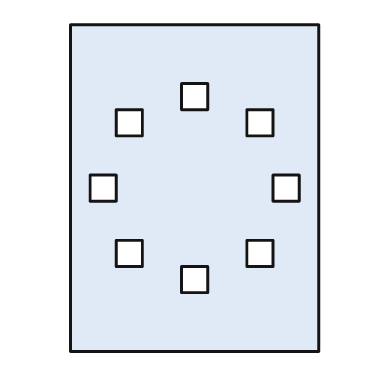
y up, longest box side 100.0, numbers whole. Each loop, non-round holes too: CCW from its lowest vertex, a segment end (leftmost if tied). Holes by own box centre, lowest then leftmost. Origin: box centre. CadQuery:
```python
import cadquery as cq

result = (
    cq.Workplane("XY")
    .moveTo(-38.0, -50.0)
    .lineTo(38.0, -50.0)
    .lineTo(38.0, 50.0)
    .lineTo(-38.0, 50.0)
    .close()
    .moveTo(-4.0, -32.0)
    .lineTo(4.0, -32.0)
    .lineTo(4.0, -24.0)
    .lineTo(-4.0, -24.0)
    .close()
    .moveTo(-24.0, -24.0)
    .lineTo(-16.0, -24.0)
    .lineTo(-16.0, -16.0)
    .lineTo(-24.0, -16.0)
    .close()
    .moveTo(16.0, -24.0)
    .lineTo(24.0, -24.0)
    .lineTo(24.0, -16.0)
    .lineTo(16.0, -16.0)
    .close()
    .moveTo(-32.0, -4.0)
    .lineTo(-24.0, -4.0)
    .lineTo(-24.0, 4.0)
    .lineTo(-32.0, 4.0)
    .close()
    .moveTo(24.0, -4.0)
    .lineTo(32.0, -4.0)
    .lineTo(32.0, 4.0)
    .lineTo(24.0, 4.0)
    .close()
    .moveTo(-24.0, 16.0)
    .lineTo(-16.0, 16.0)
    .lineTo(-16.0, 24.0)
    .lineTo(-24.0, 24.0)
    .close()
    .moveTo(16.0, 16.0)
    .lineTo(24.0, 16.0)
    .lineTo(24.0, 24.0)
    .lineTo(16.0, 24.0)
    .close()
    .moveTo(-4.0, 24.0)
    .lineTo(4.0, 24.0)
    .lineTo(4.0, 32.0)
    .lineTo(-4.0, 32.0)
    .close()
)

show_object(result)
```